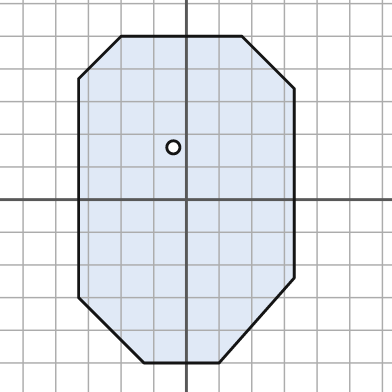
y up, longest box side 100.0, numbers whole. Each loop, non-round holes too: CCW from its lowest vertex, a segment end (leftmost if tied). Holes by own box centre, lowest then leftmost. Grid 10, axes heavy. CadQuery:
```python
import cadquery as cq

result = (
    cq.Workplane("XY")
    .moveTo(-13.0, -50.0)
    .lineTo(10.0, -50.0)
    .lineTo(33.0, -24.0)
    .lineTo(33.0, 34.0)
    .lineTo(17.0, 50.0)
    .lineTo(-20.0, 50.0)
    .lineTo(-33.0, 37.0)
    .lineTo(-33.0, -30.0)
    .close()
    .moveTo(-4.0, 16.0)
    .circle(2.0)
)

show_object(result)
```